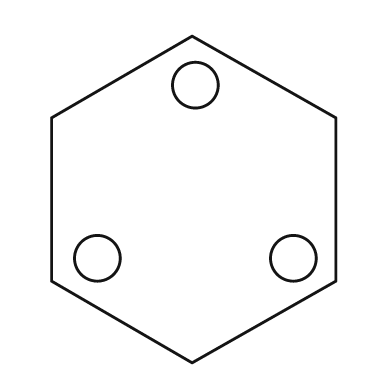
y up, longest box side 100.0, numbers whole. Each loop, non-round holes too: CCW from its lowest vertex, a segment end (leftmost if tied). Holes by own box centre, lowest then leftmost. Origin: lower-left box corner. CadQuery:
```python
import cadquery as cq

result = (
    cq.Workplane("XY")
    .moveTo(43.0, 0.0)
    .lineTo(87.0, 25.0)
    .lineTo(87.0, 75.0)
    .lineTo(43.0, 100.0)
    .lineTo(0.0, 75.0)
    .lineTo(0.0, 25.0)
    .close()
    .moveTo(14.0, 32.0)
    .circle(7.0)
    .moveTo(74.0, 32.0)
    .circle(7.0)
    .moveTo(44.0, 85.0)
    .circle(7.0)
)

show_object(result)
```